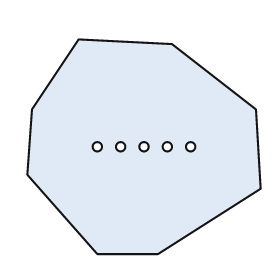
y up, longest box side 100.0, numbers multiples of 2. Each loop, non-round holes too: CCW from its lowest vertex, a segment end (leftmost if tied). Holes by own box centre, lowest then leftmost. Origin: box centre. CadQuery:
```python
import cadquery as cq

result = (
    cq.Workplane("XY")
    .moveTo(-20.0, -46.0)
    .lineTo(6.0, -46.0)
    .lineTo(50.0, -18.0)
    .lineTo(48.0, 16.0)
    .lineTo(12.0, 44.0)
    .lineTo(-28.0, 46.0)
    .lineTo(-48.0, 16.0)
    .lineTo(-50.0, -12.0)
    .close()
    .moveTo(-20.0, 0.0)
    .circle(2.0)
    .moveTo(-10.0, 0.0)
    .circle(2.0)
    .moveTo(0.0, 0.0)
    .circle(2.0)
    .moveTo(10.0, 0.0)
    .circle(2.0)
    .moveTo(20.0, 0.0)
    .circle(2.0)
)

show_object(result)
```